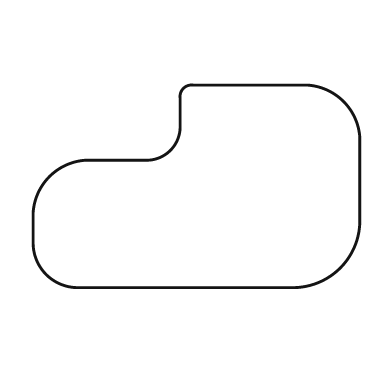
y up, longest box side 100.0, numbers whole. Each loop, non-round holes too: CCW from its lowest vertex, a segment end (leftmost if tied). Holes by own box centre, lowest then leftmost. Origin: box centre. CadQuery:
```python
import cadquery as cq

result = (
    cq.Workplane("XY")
    .moveTo(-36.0, -31.0)
    .lineTo(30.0, -31.0)
    .threePointArc((44.0, -25.0), (50.0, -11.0))
    .lineTo(50.0, 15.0)
    .threePointArc((45.0, 26.0), (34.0, 31.0))
    .lineTo(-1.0, 31.0)
    .threePointArc((-4.0, 30.0), (-5.0, 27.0))
    .lineTo(-5.0, 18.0)
    .threePointArc((-8.0, 11.0), (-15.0, 8.0))
    .lineTo(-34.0, 8.0)
    .threePointArc((-45.0, 3.0), (-50.0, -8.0))
    .lineTo(-50.0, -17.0)
    .threePointArc((-46.0, -27.0), (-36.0, -31.0))
    .close()
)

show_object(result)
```